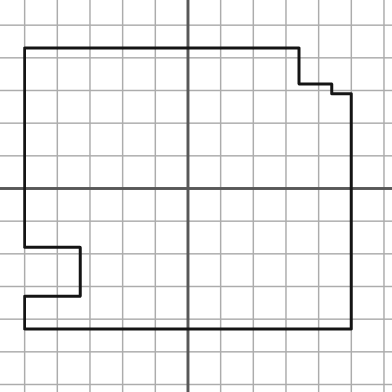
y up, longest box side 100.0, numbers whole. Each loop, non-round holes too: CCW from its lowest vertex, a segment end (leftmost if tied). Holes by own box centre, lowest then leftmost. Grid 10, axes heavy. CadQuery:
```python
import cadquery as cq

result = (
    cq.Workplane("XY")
    .moveTo(-50.0, -43.0)
    .lineTo(50.0, -43.0)
    .lineTo(50.0, 29.0)
    .lineTo(44.0, 29.0)
    .lineTo(44.0, 32.0)
    .lineTo(34.0, 32.0)
    .lineTo(34.0, 43.0)
    .lineTo(-50.0, 43.0)
    .lineTo(-50.0, -18.0)
    .lineTo(-33.0, -18.0)
    .lineTo(-33.0, -33.0)
    .lineTo(-50.0, -33.0)
    .close()
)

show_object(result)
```